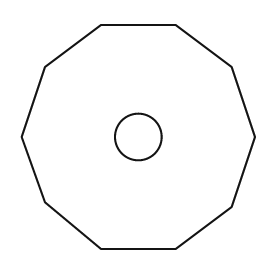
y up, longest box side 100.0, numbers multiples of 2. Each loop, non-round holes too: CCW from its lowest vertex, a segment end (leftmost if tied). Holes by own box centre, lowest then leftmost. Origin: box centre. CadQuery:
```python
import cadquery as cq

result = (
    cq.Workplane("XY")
    .moveTo(-16.0, -48.0)
    .lineTo(16.0, -48.0)
    .lineTo(40.0, -30.0)
    .lineTo(50.0, 0.0)
    .lineTo(40.0, 30.0)
    .lineTo(16.0, 48.0)
    .lineTo(-16.0, 48.0)
    .lineTo(-40.0, 30.0)
    .lineTo(-50.0, 0.0)
    .lineTo(-40.0, -28.0)
    .close()
    .moveTo(0.0, 0.0)
    .circle(10.0)
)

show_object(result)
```